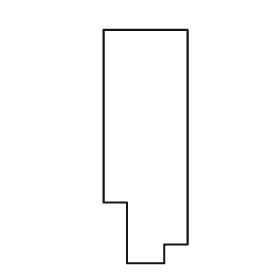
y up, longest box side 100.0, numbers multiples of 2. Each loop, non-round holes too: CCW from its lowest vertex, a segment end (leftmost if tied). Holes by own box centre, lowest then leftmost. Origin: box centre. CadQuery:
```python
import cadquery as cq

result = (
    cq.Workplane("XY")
    .moveTo(-8.0, -50.0)
    .lineTo(8.0, -50.0)
    .lineTo(8.0, -42.0)
    .lineTo(18.0, -42.0)
    .lineTo(18.0, 50.0)
    .lineTo(-18.0, 50.0)
    .lineTo(-18.0, -24.0)
    .lineTo(-8.0, -24.0)
    .close()
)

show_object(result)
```